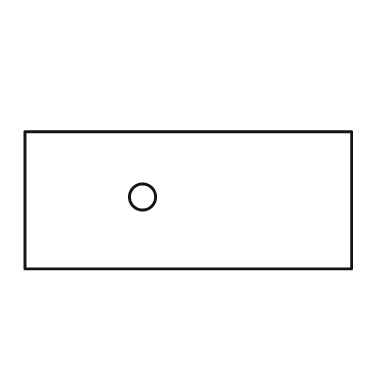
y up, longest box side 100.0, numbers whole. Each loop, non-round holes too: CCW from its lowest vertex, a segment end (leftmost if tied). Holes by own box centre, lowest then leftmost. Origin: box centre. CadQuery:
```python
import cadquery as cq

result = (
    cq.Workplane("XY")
    .moveTo(-50.0, -21.0)
    .lineTo(50.0, -21.0)
    .lineTo(50.0, 21.0)
    .lineTo(-50.0, 21.0)
    .close()
    .moveTo(-14.0, 1.0)
    .circle(4.0)
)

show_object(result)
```